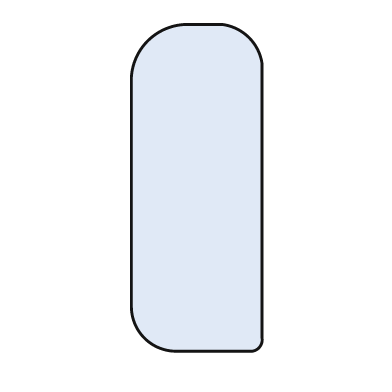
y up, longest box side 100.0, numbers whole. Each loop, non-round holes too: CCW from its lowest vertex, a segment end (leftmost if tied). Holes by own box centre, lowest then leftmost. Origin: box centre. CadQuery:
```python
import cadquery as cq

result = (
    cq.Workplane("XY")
    .moveTo(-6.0, -50.0)
    .lineTo(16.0, -50.0)
    .threePointArc((19.0, -49.0), (20.0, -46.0))
    .lineTo(20.0, 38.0)
    .threePointArc((16.0, 46.0), (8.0, 50.0))
    .lineTo(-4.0, 50.0)
    .threePointArc((-15.0, 45.0), (-20.0, 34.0))
    .lineTo(-20.0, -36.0)
    .threePointArc((-16.0, -46.0), (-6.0, -50.0))
    .close()
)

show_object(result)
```